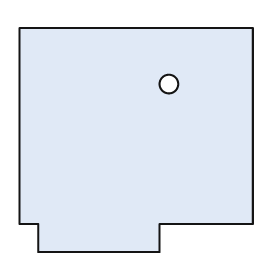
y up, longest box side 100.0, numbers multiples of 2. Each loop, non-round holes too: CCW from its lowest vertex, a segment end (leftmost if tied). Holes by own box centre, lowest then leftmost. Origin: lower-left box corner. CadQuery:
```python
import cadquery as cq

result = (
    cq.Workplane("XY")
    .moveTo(8.0, 0.0)
    .lineTo(60.0, 0.0)
    .lineTo(60.0, 12.0)
    .lineTo(100.0, 12.0)
    .lineTo(100.0, 96.0)
    .lineTo(0.0, 96.0)
    .lineTo(0.0, 12.0)
    .lineTo(8.0, 12.0)
    .close()
    .moveTo(64.0, 72.0)
    .circle(4.0)
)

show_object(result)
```